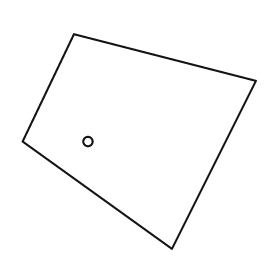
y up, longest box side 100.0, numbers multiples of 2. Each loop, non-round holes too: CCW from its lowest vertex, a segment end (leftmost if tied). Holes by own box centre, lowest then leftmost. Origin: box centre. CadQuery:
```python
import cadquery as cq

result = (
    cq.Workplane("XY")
    .moveTo(14.0, -46.0)
    .lineTo(50.0, 26.0)
    .lineTo(-28.0, 46.0)
    .lineTo(-50.0, 0.0)
    .close()
    .moveTo(-22.0, 0.0)
    .circle(2.0)
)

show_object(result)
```